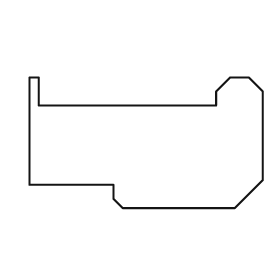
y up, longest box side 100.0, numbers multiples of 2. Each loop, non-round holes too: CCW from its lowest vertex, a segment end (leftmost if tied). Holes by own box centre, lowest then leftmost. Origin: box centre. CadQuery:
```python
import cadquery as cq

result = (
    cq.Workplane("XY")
    .moveTo(-10.0, -28.0)
    .lineTo(38.0, -28.0)
    .lineTo(50.0, -16.0)
    .lineTo(50.0, 22.0)
    .lineTo(44.0, 28.0)
    .lineTo(36.0, 28.0)
    .lineTo(30.0, 22.0)
    .lineTo(30.0, 16.0)
    .lineTo(-46.0, 16.0)
    .lineTo(-46.0, 28.0)
    .lineTo(-50.0, 28.0)
    .lineTo(-50.0, -18.0)
    .lineTo(-14.0, -18.0)
    .lineTo(-14.0, -24.0)
    .close()
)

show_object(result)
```